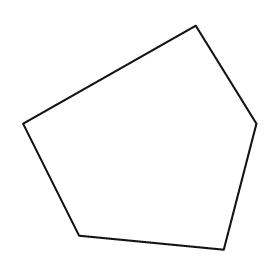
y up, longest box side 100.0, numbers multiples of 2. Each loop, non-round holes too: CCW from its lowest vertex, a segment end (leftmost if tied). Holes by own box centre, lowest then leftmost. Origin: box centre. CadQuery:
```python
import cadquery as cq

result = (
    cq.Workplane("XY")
    .moveTo(36.0, -48.0)
    .lineTo(50.0, 6.0)
    .lineTo(24.0, 48.0)
    .lineTo(-50.0, 6.0)
    .lineTo(-26.0, -42.0)
    .close()
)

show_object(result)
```